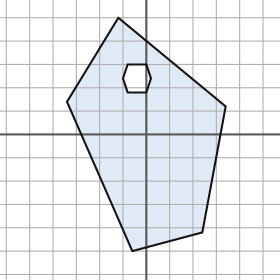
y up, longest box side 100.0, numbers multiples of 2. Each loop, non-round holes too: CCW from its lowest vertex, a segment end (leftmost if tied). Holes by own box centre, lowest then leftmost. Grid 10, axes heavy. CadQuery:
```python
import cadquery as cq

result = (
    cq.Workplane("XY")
    .moveTo(-6.0, -50.0)
    .lineTo(24.0, -42.0)
    .lineTo(34.0, 12.0)
    .lineTo(-12.0, 50.0)
    .lineTo(-34.0, 14.0)
    .close()
    .moveTo(-8.0, 18.0)
    .lineTo(0.0, 18.0)
    .lineTo(2.0, 24.0)
    .lineTo(0.0, 30.0)
    .lineTo(-8.0, 30.0)
    .lineTo(-10.0, 24.0)
    .close()
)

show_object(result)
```